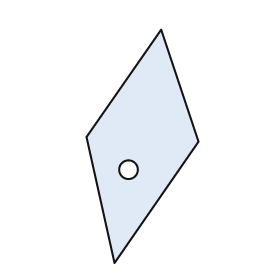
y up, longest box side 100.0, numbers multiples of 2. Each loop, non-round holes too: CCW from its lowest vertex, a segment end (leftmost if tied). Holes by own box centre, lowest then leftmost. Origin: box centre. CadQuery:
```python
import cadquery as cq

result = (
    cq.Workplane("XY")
    .moveTo(-12.0, -50.0)
    .lineTo(24.0, 2.0)
    .lineTo(8.0, 50.0)
    .lineTo(-24.0, 4.0)
    .close()
    .moveTo(-6.0, -10.0)
    .circle(4.0)
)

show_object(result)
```